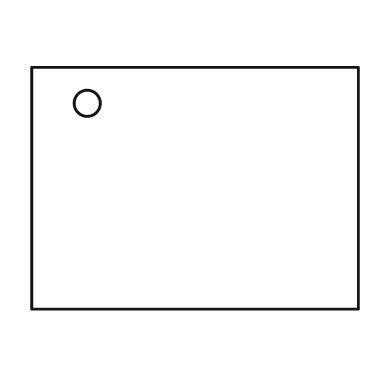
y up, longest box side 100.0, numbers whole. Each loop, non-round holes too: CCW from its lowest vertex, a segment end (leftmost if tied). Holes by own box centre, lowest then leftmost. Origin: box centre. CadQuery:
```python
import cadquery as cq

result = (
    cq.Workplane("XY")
    .moveTo(-50.0, -37.0)
    .lineTo(50.0, -37.0)
    .lineTo(50.0, 37.0)
    .lineTo(-50.0, 37.0)
    .close()
    .moveTo(-33.0, 26.0)
    .circle(4.0)
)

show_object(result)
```